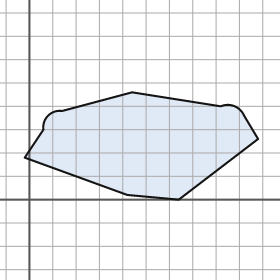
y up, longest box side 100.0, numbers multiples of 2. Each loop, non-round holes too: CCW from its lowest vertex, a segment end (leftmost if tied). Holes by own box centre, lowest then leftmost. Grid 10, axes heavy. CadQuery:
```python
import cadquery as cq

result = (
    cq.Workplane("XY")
    .moveTo(64.0, 0.0)
    .lineTo(98.0, 26.0)
    .lineTo(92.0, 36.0)
    .threePointArc((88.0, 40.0), (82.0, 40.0))
    .lineTo(44.0, 46.0)
    .lineTo(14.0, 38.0)
    .threePointArc((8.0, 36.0), (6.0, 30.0))
    .lineTo(-2.0, 18.0)
    .lineTo(42.0, 2.0)
    .close()
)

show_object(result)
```